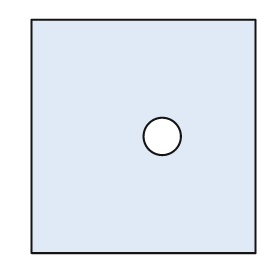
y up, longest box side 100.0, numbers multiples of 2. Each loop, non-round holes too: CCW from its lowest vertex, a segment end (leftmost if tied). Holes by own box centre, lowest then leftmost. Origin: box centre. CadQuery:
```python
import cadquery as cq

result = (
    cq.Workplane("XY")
    .moveTo(-48.0, -50.0)
    .lineTo(48.0, -50.0)
    .lineTo(48.0, 50.0)
    .lineTo(-48.0, 50.0)
    .close()
    .moveTo(8.0, 0.0)
    .circle(8.0)
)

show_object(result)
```